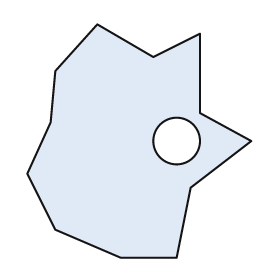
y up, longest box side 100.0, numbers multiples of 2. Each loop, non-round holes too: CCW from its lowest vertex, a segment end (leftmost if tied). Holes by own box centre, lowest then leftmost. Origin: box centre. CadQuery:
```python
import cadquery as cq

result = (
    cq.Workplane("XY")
    .moveTo(-8.0, -50.0)
    .lineTo(16.0, -50.0)
    .lineTo(22.0, -20.0)
    .lineTo(48.0, 0.0)
    .lineTo(26.0, 12.0)
    .lineTo(26.0, 46.0)
    .lineTo(6.0, 36.0)
    .lineTo(-18.0, 50.0)
    .lineTo(-36.0, 30.0)
    .lineTo(-38.0, 8.0)
    .lineTo(-48.0, -14.0)
    .lineTo(-36.0, -38.0)
    .close()
    .moveTo(16.0, 0.0)
    .circle(10.0)
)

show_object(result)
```